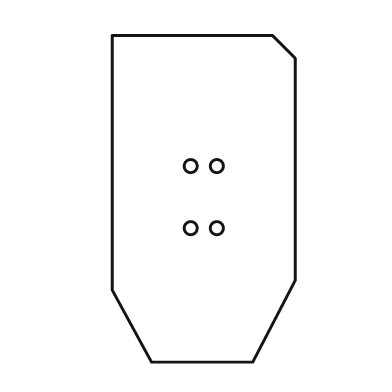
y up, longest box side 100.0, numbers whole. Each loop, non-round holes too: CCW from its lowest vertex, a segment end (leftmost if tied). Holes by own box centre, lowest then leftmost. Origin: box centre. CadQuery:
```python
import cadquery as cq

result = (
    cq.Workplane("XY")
    .moveTo(-16.0, -50.0)
    .lineTo(15.0, -50.0)
    .lineTo(28.0, -25.0)
    .lineTo(28.0, 43.0)
    .lineTo(21.0, 50.0)
    .lineTo(-28.0, 50.0)
    .lineTo(-28.0, -28.0)
    .close()
    .moveTo(-4.0, -9.0)
    .circle(2.0)
    .moveTo(4.0, -9.0)
    .circle(2.0)
    .moveTo(-4.0, 10.0)
    .circle(2.0)
    .moveTo(4.0, 10.0)
    .circle(2.0)
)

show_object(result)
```